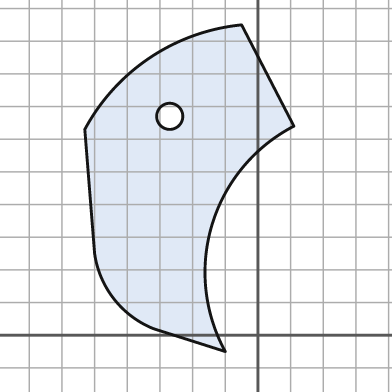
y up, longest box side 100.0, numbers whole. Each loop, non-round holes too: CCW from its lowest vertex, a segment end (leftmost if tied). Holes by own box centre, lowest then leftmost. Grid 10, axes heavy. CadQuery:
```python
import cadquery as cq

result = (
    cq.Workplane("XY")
    .moveTo(-10.0, -5.0)
    .threePointArc((-14.0, 34.0), (11.0, 64.0))
    .lineTo(-5.0, 95.0)
    .threePointArc((-33.0, 85.0), (-53.0, 63.0))
    .lineTo(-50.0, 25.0)
    .threePointArc((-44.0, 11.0), (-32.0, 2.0))
    .close()
    .moveTo(-27.0, 67.0)
    .circle(4.0)
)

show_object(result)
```